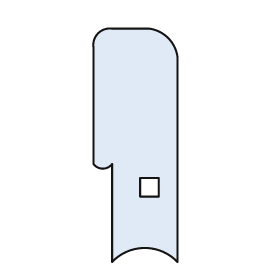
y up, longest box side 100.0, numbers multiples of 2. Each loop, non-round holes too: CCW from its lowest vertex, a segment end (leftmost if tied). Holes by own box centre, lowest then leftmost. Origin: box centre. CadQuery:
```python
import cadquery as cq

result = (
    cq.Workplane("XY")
    .moveTo(-10.0, -50.0)
    .threePointArc((4.0, -44.0), (18.0, -50.0))
    .lineTo(18.0, 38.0)
    .threePointArc((14.0, 46.0), (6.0, 50.0))
    .lineTo(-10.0, 50.0)
    .threePointArc((-16.0, 48.0), (-18.0, 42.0))
    .lineTo(-18.0, -8.0)
    .threePointArc((-14.0, -10.0), (-10.0, -8.0))
    .close()
    .moveTo(2.0, -22.0)
    .lineTo(10.0, -22.0)
    .lineTo(10.0, -14.0)
    .lineTo(2.0, -14.0)
    .close()
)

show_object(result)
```